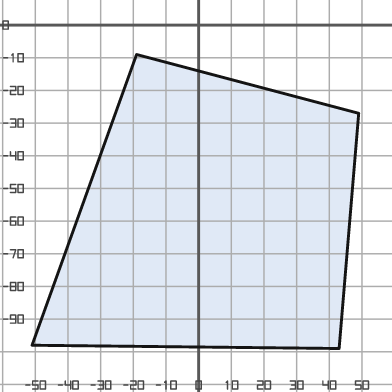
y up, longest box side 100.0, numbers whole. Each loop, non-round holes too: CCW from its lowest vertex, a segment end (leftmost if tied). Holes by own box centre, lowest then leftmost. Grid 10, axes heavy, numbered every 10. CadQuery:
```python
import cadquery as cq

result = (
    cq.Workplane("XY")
    .moveTo(43.0, -99.0)
    .lineTo(49.0, -27.0)
    .lineTo(-19.0, -9.0)
    .lineTo(-51.0, -98.0)
    .close()
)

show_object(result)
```